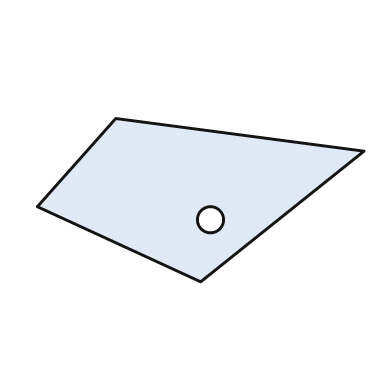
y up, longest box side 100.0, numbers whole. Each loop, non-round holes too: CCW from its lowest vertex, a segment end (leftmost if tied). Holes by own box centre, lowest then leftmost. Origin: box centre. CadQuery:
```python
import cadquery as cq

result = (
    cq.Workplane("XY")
    .moveTo(0.0, -25.0)
    .lineTo(50.0, 15.0)
    .lineTo(-26.0, 25.0)
    .lineTo(-50.0, -2.0)
    .close()
    .moveTo(3.0, -6.0)
    .circle(4.0)
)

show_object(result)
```